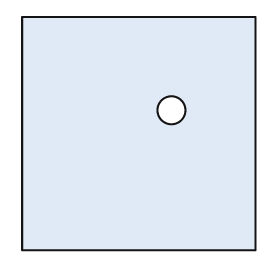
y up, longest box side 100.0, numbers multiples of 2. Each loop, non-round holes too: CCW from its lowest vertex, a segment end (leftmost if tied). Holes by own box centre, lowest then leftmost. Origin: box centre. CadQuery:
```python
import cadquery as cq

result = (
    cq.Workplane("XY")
    .moveTo(-50.0, -50.0)
    .lineTo(50.0, -50.0)
    .lineTo(50.0, 50.0)
    .lineTo(-50.0, 50.0)
    .close()
    .moveTo(14.0, 10.0)
    .circle(6.0)
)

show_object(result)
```